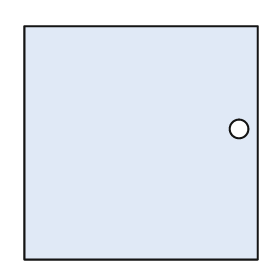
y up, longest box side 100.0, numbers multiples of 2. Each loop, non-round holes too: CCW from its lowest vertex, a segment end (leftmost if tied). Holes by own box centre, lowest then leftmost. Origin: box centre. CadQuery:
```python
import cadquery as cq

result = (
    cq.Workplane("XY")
    .moveTo(-50.0, -50.0)
    .lineTo(50.0, -50.0)
    .lineTo(50.0, 50.0)
    .lineTo(-50.0, 50.0)
    .close()
    .moveTo(42.0, 6.0)
    .circle(4.0)
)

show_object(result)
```